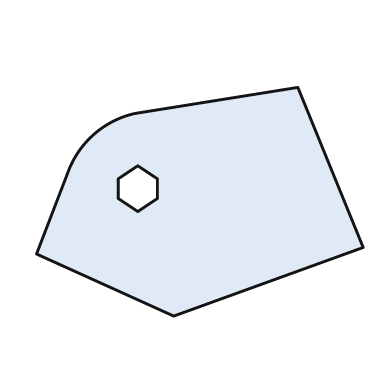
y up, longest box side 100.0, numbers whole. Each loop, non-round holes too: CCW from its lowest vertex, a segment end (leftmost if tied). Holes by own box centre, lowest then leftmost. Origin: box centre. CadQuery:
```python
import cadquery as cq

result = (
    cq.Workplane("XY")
    .moveTo(-8.0, -35.0)
    .lineTo(50.0, -14.0)
    .lineTo(30.0, 35.0)
    .lineTo(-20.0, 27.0)
    .threePointArc((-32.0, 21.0), (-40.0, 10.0))
    .lineTo(-50.0, -16.0)
    .close()
    .moveTo(-19.0, -3.0)
    .lineTo(-13.0, 1.0)
    .lineTo(-13.0, 7.0)
    .lineTo(-19.0, 11.0)
    .lineTo(-25.0, 7.0)
    .lineTo(-25.0, 1.0)
    .close()
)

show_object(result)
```